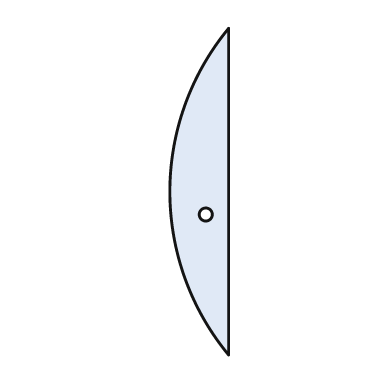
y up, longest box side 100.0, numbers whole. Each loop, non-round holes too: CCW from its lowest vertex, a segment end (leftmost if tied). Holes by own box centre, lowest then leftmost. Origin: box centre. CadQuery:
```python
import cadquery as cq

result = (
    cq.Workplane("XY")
    .moveTo(9.0, -50.0)
    .lineTo(9.0, 50.0)
    .threePointArc((-9.0, 0.0), (9.0, -50.0))
    .close()
    .moveTo(2.0, -7.0)
    .circle(2.0)
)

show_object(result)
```